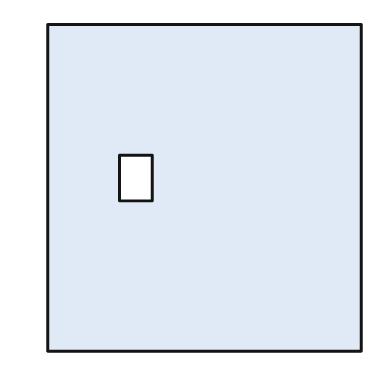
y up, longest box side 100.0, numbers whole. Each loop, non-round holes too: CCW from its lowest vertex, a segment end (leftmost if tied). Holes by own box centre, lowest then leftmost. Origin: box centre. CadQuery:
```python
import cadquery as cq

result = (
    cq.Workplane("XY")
    .moveTo(-48.0, -50.0)
    .lineTo(48.0, -50.0)
    .lineTo(48.0, 50.0)
    .lineTo(-48.0, 50.0)
    .close()
    .moveTo(-26.0, -4.0)
    .lineTo(-16.0, -4.0)
    .lineTo(-16.0, 10.0)
    .lineTo(-26.0, 10.0)
    .close()
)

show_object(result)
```